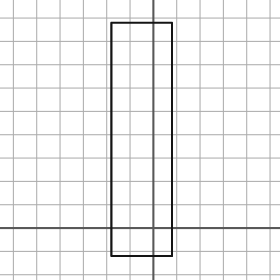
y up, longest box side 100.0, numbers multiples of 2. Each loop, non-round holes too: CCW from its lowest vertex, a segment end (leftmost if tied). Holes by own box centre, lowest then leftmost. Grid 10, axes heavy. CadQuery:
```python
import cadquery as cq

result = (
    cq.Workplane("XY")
    .moveTo(-18.0, -12.0)
    .lineTo(8.0, -12.0)
    .lineTo(8.0, 88.0)
    .lineTo(-18.0, 88.0)
    .close()
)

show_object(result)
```